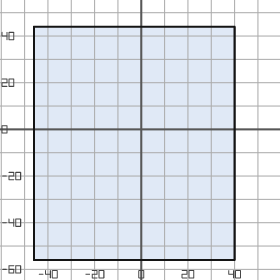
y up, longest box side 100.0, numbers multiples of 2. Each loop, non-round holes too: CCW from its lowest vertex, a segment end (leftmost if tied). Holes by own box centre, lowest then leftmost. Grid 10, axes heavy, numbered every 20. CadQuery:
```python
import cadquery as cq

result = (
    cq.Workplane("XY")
    .moveTo(-46.0, -56.0)
    .lineTo(40.0, -56.0)
    .lineTo(40.0, 44.0)
    .lineTo(-46.0, 44.0)
    .close()
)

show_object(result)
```